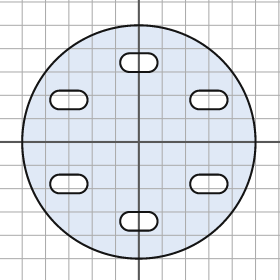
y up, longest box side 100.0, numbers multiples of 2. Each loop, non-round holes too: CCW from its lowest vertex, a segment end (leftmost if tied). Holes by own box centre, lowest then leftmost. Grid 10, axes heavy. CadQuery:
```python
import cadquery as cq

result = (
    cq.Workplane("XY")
    .moveTo(0.0, 0.0)
    .circle(50.0)
    .moveTo(-4.0, -38.0)
    .lineTo(4.0, -38.0)
    .threePointArc((8.0, -34.0), (4.0, -30.0))
    .lineTo(-4.0, -30.0)
    .threePointArc((-8.0, -34.0), (-4.0, -38.0))
    .close()
    .moveTo(-34.0, -22.0)
    .lineTo(-26.0, -22.0)
    .threePointArc((-22.0, -18.0), (-26.0, -14.0))
    .lineTo(-34.0, -14.0)
    .threePointArc((-38.0, -18.0), (-34.0, -22.0))
    .close()
    .moveTo(26.0, -22.0)
    .lineTo(34.0, -22.0)
    .threePointArc((38.0, -18.0), (34.0, -14.0))
    .lineTo(26.0, -14.0)
    .threePointArc((22.0, -18.0), (26.0, -22.0))
    .close()
    .moveTo(-34.0, 14.0)
    .lineTo(-26.0, 14.0)
    .threePointArc((-22.0, 18.0), (-26.0, 22.0))
    .lineTo(-34.0, 22.0)
    .threePointArc((-38.0, 18.0), (-34.0, 14.0))
    .close()
    .moveTo(26.0, 14.0)
    .lineTo(34.0, 14.0)
    .threePointArc((38.0, 18.0), (34.0, 22.0))
    .lineTo(26.0, 22.0)
    .threePointArc((22.0, 18.0), (26.0, 14.0))
    .close()
    .moveTo(-4.0, 30.0)
    .lineTo(4.0, 30.0)
    .threePointArc((8.0, 34.0), (4.0, 38.0))
    .lineTo(-4.0, 38.0)
    .threePointArc((-8.0, 34.0), (-4.0, 30.0))
    .close()
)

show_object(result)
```